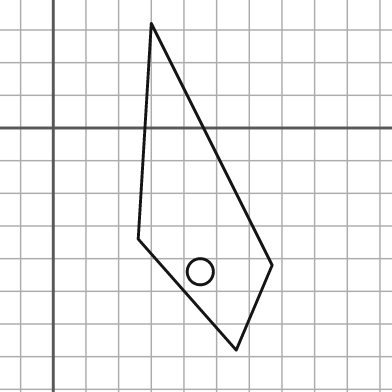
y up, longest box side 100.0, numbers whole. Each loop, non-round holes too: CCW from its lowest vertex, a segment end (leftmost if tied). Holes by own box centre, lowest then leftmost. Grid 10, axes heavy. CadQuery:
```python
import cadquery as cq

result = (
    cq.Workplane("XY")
    .moveTo(56.0, -68.0)
    .lineTo(67.0, -42.0)
    .lineTo(30.0, 32.0)
    .lineTo(26.0, -34.0)
    .close()
    .moveTo(45.0, -44.0)
    .circle(4.0)
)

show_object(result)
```